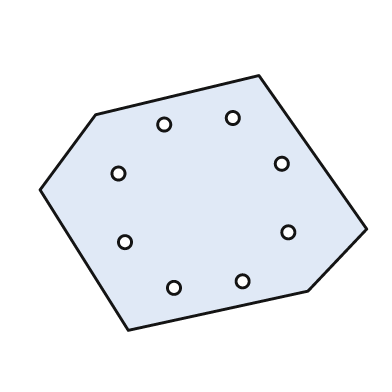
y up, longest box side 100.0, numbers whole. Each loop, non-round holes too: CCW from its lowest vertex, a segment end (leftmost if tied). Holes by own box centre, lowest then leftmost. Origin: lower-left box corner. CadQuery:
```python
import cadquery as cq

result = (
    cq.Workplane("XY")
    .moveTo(27.0, 0.0)
    .lineTo(82.0, 12.0)
    .lineTo(100.0, 31.0)
    .lineTo(67.0, 78.0)
    .lineTo(17.0, 66.0)
    .lineTo(0.0, 43.0)
    .close()
    .moveTo(41.0, 13.0)
    .circle(2.0)
    .moveTo(62.0, 15.0)
    .circle(2.0)
    .moveTo(26.0, 27.0)
    .circle(2.0)
    .moveTo(76.0, 30.0)
    .circle(2.0)
    .moveTo(24.0, 48.0)
    .circle(2.0)
    .moveTo(74.0, 51.0)
    .circle(2.0)
    .moveTo(38.0, 63.0)
    .circle(2.0)
    .moveTo(59.0, 65.0)
    .circle(2.0)
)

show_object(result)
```